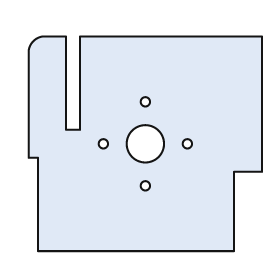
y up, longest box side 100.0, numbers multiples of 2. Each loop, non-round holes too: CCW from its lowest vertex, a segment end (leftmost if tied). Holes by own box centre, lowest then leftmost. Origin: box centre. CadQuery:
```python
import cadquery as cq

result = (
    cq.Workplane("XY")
    .moveTo(-46.0, -46.0)
    .lineTo(38.0, -46.0)
    .lineTo(38.0, -12.0)
    .lineTo(50.0, -12.0)
    .lineTo(50.0, 46.0)
    .lineTo(-28.0, 46.0)
    .lineTo(-28.0, 6.0)
    .lineTo(-34.0, 6.0)
    .lineTo(-34.0, 46.0)
    .lineTo(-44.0, 46.0)
    .threePointArc((-48.0, 44.0), (-50.0, 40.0))
    .lineTo(-50.0, -6.0)
    .lineTo(-46.0, -6.0)
    .close()
    .moveTo(0.0, -18.0)
    .circle(2.0)
    .moveTo(-18.0, 0.0)
    .circle(2.0)
    .moveTo(0.0, 0.0)
    .circle(8.0)
    .moveTo(18.0, 0.0)
    .circle(2.0)
    .moveTo(0.0, 18.0)
    .circle(2.0)
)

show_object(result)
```